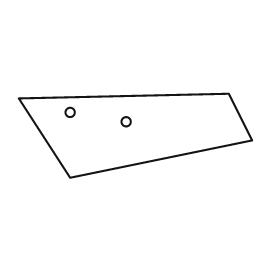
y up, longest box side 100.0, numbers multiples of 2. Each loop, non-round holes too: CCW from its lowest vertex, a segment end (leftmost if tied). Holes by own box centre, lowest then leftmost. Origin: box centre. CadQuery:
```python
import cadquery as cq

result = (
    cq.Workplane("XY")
    .moveTo(-28.0, -18.0)
    .lineTo(50.0, -2.0)
    .lineTo(40.0, 18.0)
    .lineTo(-50.0, 16.0)
    .close()
    .moveTo(-4.0, 6.0)
    .circle(2.0)
    .moveTo(-28.0, 10.0)
    .circle(2.0)
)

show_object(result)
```